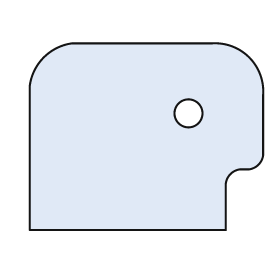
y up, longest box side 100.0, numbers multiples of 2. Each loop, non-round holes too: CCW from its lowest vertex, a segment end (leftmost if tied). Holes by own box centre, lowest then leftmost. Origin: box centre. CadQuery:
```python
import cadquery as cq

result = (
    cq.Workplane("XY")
    .moveTo(-50.0, -40.0)
    .lineTo(34.0, -40.0)
    .lineTo(34.0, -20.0)
    .threePointArc((36.0, -16.0), (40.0, -14.0))
    .lineTo(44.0, -14.0)
    .threePointArc((48.0, -12.0), (50.0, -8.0))
    .lineTo(50.0, 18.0)
    .threePointArc((44.0, 34.0), (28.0, 40.0))
    .lineTo(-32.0, 40.0)
    .threePointArc((-44.0, 34.0), (-50.0, 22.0))
    .close()
    .moveTo(18.0, 10.0)
    .circle(6.0)
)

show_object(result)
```